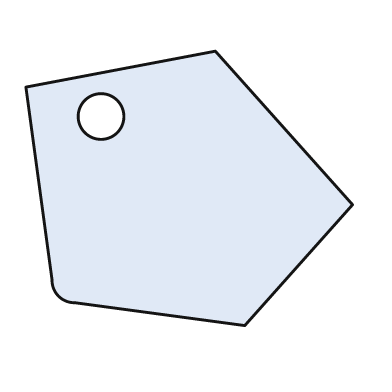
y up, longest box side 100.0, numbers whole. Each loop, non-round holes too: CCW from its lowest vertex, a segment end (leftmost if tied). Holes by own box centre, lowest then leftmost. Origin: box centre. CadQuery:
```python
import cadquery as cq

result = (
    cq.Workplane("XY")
    .moveTo(17.0, -42.0)
    .lineTo(50.0, -5.0)
    .lineTo(8.0, 42.0)
    .lineTo(-50.0, 31.0)
    .lineTo(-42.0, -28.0)
    .threePointArc((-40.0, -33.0), (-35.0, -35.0))
    .close()
    .moveTo(-27.0, 22.0)
    .circle(7.0)
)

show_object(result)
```